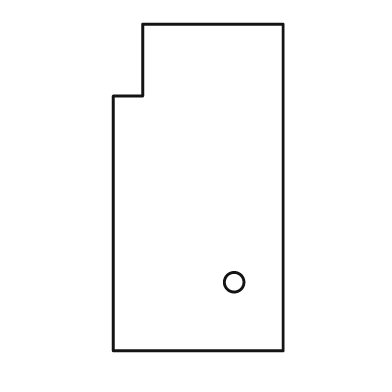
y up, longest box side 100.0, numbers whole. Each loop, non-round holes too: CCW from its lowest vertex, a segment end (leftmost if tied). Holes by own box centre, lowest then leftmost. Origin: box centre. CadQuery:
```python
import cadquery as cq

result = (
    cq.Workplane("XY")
    .moveTo(-26.0, -50.0)
    .lineTo(26.0, -50.0)
    .lineTo(26.0, 50.0)
    .lineTo(-17.0, 50.0)
    .lineTo(-17.0, 28.0)
    .lineTo(-26.0, 28.0)
    .close()
    .moveTo(11.0, -29.0)
    .circle(3.0)
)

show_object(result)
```